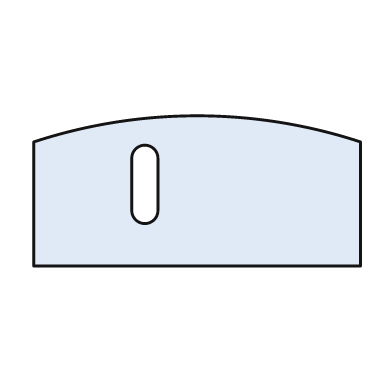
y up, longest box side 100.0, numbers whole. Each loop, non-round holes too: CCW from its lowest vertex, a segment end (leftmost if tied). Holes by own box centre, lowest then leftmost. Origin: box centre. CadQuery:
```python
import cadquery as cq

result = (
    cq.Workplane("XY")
    .moveTo(-50.0, -23.0)
    .lineTo(50.0, -23.0)
    .lineTo(50.0, 15.0)
    .threePointArc((0.0, 23.0), (-50.0, 15.0))
    .close()
    .moveTo(-20.0, -6.0)
    .threePointArc((-16.0, -10.0), (-12.0, -6.0))
    .lineTo(-12.0, 10.0)
    .threePointArc((-16.0, 14.0), (-20.0, 10.0))
    .close()
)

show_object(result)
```